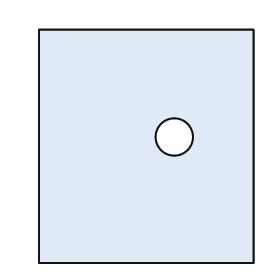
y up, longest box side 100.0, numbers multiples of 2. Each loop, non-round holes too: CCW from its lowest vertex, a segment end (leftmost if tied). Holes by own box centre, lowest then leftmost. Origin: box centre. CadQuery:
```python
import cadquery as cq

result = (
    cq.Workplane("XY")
    .moveTo(-46.0, -50.0)
    .lineTo(46.0, -50.0)
    .lineTo(46.0, 50.0)
    .lineTo(-46.0, 50.0)
    .close()
    .moveTo(12.0, 4.0)
    .circle(8.0)
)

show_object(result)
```